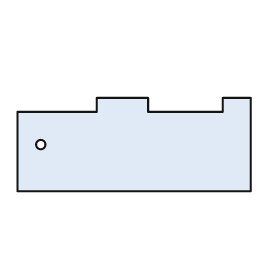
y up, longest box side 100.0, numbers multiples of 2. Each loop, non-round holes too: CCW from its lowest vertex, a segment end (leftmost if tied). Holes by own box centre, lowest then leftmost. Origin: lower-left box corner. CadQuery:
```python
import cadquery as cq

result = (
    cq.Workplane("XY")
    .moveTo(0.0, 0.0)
    .lineTo(100.0, 0.0)
    .lineTo(100.0, 40.0)
    .lineTo(88.0, 40.0)
    .lineTo(88.0, 34.0)
    .lineTo(56.0, 34.0)
    .lineTo(56.0, 40.0)
    .lineTo(34.0, 40.0)
    .lineTo(34.0, 34.0)
    .lineTo(0.0, 34.0)
    .close()
    .moveTo(10.0, 20.0)
    .circle(2.0)
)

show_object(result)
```